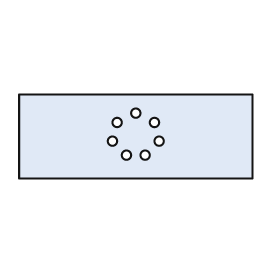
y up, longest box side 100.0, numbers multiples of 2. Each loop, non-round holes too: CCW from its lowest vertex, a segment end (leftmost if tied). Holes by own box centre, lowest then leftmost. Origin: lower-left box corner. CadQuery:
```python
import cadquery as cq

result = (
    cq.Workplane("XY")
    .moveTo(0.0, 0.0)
    .lineTo(100.0, 0.0)
    .lineTo(100.0, 36.0)
    .lineTo(0.0, 36.0)
    .close()
    .moveTo(46.0, 10.0)
    .circle(2.0)
    .moveTo(54.0, 10.0)
    .circle(2.0)
    .moveTo(40.0, 16.0)
    .circle(2.0)
    .moveTo(60.0, 16.0)
    .circle(2.0)
    .moveTo(42.0, 24.0)
    .circle(2.0)
    .moveTo(58.0, 24.0)
    .circle(2.0)
    .moveTo(50.0, 28.0)
    .circle(2.0)
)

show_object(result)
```